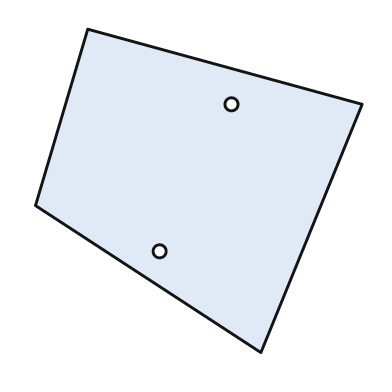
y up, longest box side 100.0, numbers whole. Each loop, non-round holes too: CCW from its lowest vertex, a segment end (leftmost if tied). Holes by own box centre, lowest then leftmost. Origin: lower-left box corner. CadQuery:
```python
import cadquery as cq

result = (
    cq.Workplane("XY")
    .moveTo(69.0, 0.0)
    .lineTo(100.0, 76.0)
    .lineTo(16.0, 99.0)
    .lineTo(0.0, 45.0)
    .close()
    .moveTo(38.0, 31.0)
    .circle(2.0)
    .moveTo(60.0, 76.0)
    .circle(2.0)
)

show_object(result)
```